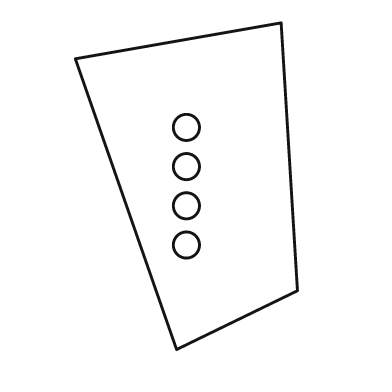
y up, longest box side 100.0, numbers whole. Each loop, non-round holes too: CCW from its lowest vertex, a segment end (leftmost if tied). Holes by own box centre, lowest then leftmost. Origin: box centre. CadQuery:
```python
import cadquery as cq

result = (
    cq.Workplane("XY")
    .moveTo(-3.0, -50.0)
    .lineTo(34.0, -32.0)
    .lineTo(29.0, 50.0)
    .lineTo(-34.0, 39.0)
    .close()
    .moveTo(0.0, -18.0)
    .circle(4.0)
    .moveTo(0.0, -6.0)
    .circle(4.0)
    .moveTo(0.0, 6.0)
    .circle(4.0)
    .moveTo(0.0, 18.0)
    .circle(4.0)
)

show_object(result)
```